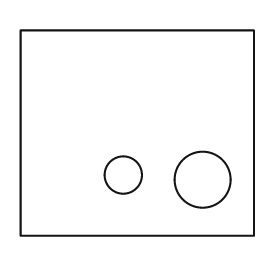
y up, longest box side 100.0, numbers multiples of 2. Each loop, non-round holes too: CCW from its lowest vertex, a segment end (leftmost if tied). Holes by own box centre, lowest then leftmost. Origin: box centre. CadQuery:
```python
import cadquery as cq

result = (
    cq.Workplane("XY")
    .moveTo(-50.0, -44.0)
    .lineTo(50.0, -44.0)
    .lineTo(50.0, 44.0)
    .lineTo(-50.0, 44.0)
    .close()
    .moveTo(28.0, -20.0)
    .circle(12.0)
    .moveTo(-6.0, -18.0)
    .circle(8.0)
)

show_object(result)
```